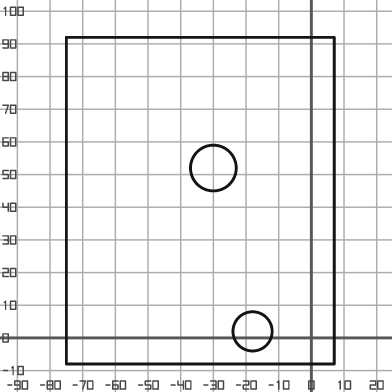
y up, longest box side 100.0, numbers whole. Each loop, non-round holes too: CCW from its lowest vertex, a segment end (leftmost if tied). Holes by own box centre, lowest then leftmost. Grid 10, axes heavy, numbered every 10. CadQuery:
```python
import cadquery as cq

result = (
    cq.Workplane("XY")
    .moveTo(-75.0, -8.0)
    .lineTo(7.0, -8.0)
    .lineTo(7.0, 92.0)
    .lineTo(-75.0, 92.0)
    .close()
    .moveTo(-18.0, 2.0)
    .circle(6.0)
    .moveTo(-30.0, 52.0)
    .circle(7.0)
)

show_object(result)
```